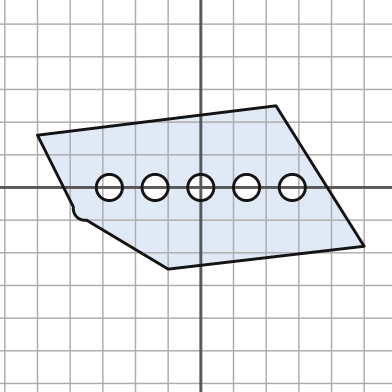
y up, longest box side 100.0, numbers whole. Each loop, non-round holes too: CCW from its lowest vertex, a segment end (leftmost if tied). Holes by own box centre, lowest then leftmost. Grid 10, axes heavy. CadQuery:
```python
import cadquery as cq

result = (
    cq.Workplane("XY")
    .moveTo(-10.0, -25.0)
    .lineTo(50.0, -18.0)
    .lineTo(23.0, 25.0)
    .lineTo(-50.0, 16.0)
    .lineTo(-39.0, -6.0)
    .threePointArc((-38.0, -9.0), (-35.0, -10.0))
    .close()
    .moveTo(-28.0, 0.0)
    .circle(4.0)
    .moveTo(-14.0, 0.0)
    .circle(4.0)
    .moveTo(0.0, 0.0)
    .circle(4.0)
    .moveTo(14.0, 0.0)
    .circle(4.0)
    .moveTo(28.0, 0.0)
    .circle(4.0)
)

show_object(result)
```